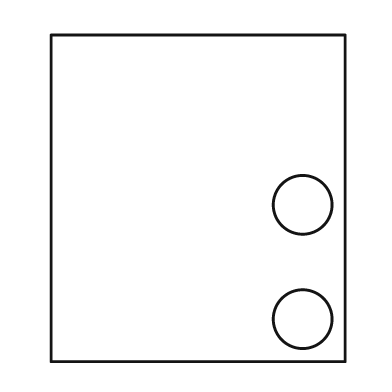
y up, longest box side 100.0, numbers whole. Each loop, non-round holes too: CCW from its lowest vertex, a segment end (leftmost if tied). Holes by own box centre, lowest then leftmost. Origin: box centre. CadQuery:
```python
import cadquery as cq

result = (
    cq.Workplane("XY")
    .moveTo(-45.0, -50.0)
    .lineTo(45.0, -50.0)
    .lineTo(45.0, 50.0)
    .lineTo(-45.0, 50.0)
    .close()
    .moveTo(32.0, -37.0)
    .circle(9.0)
    .moveTo(32.0, -2.0)
    .circle(9.0)
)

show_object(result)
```